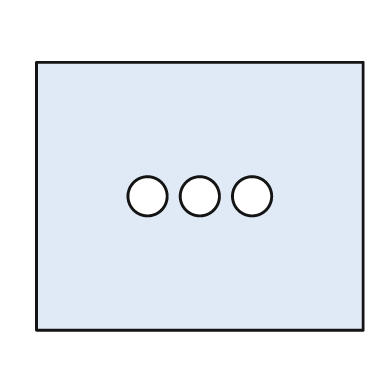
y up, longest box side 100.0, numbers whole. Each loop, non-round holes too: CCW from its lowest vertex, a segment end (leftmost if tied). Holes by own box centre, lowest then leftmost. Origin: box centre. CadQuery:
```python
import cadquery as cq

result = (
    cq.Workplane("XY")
    .moveTo(-50.0, -41.0)
    .lineTo(50.0, -41.0)
    .lineTo(50.0, 41.0)
    .lineTo(-50.0, 41.0)
    .close()
    .moveTo(-16.0, 0.0)
    .circle(6.0)
    .moveTo(0.0, 0.0)
    .circle(6.0)
    .moveTo(16.0, 0.0)
    .circle(6.0)
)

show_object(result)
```